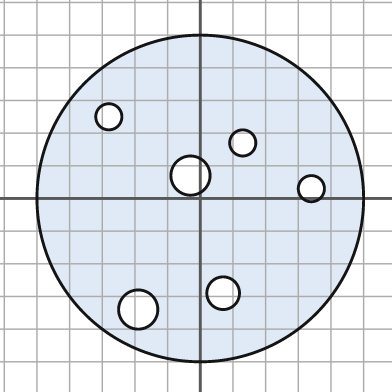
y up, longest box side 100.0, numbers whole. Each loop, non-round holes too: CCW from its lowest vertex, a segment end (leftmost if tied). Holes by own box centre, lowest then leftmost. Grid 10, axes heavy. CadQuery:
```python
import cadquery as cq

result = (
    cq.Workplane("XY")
    .moveTo(0.0, 0.0)
    .circle(50.0)
    .moveTo(-19.0, -34.0)
    .circle(6.0)
    .moveTo(7.0, -29.0)
    .circle(5.0)
    .moveTo(34.0, 3.0)
    .circle(4.0)
    .moveTo(-3.0, 7.0)
    .circle(6.0)
    .moveTo(13.0, 17.0)
    .circle(4.0)
    .moveTo(-28.0, 25.0)
    .circle(4.0)
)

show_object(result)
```